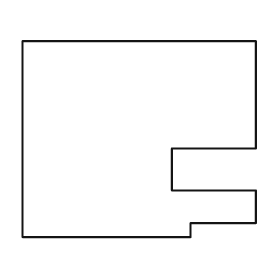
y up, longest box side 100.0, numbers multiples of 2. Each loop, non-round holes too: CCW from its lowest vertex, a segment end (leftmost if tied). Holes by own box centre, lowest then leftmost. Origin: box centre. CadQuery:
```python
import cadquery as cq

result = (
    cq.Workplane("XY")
    .moveTo(-50.0, -42.0)
    .lineTo(22.0, -42.0)
    .lineTo(22.0, -36.0)
    .lineTo(50.0, -36.0)
    .lineTo(50.0, -22.0)
    .lineTo(14.0, -22.0)
    .lineTo(14.0, -4.0)
    .lineTo(50.0, -4.0)
    .lineTo(50.0, 42.0)
    .lineTo(-50.0, 42.0)
    .close()
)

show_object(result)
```